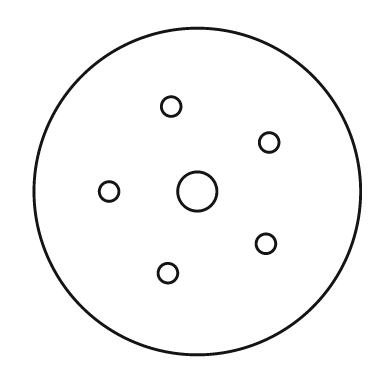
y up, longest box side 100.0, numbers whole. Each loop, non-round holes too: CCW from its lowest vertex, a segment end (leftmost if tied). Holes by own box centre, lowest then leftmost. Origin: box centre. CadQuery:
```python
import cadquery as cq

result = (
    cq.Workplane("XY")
    .moveTo(0.0, 0.0)
    .circle(50.0)
    .moveTo(-9.0, -25.0)
    .circle(3.0)
    .moveTo(21.0, -16.0)
    .circle(3.0)
    .moveTo(-27.0, 0.0)
    .circle(3.0)
    .moveTo(0.0, 0.0)
    .circle(6.0)
    .moveTo(22.0, 15.0)
    .circle(3.0)
    .moveTo(-8.0, 26.0)
    .circle(3.0)
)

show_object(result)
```